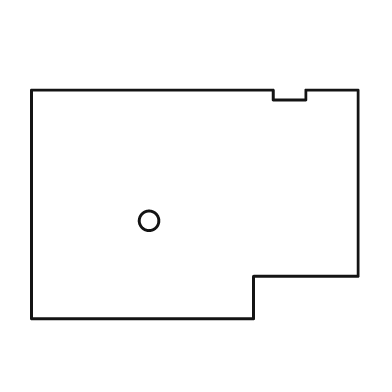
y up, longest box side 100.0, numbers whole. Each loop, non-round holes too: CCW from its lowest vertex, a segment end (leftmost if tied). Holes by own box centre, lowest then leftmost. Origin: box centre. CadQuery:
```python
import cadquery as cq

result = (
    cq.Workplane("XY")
    .moveTo(-50.0, -35.0)
    .lineTo(18.0, -35.0)
    .lineTo(18.0, -22.0)
    .lineTo(50.0, -22.0)
    .lineTo(50.0, 35.0)
    .lineTo(34.0, 35.0)
    .lineTo(34.0, 32.0)
    .lineTo(24.0, 32.0)
    .lineTo(24.0, 35.0)
    .lineTo(-50.0, 35.0)
    .close()
    .moveTo(-14.0, -5.0)
    .circle(3.0)
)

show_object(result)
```